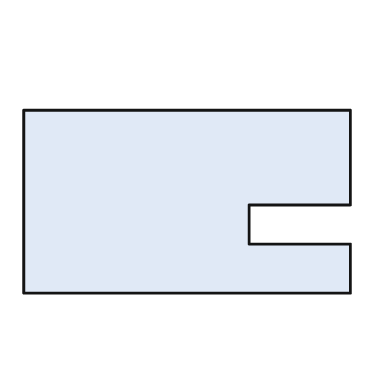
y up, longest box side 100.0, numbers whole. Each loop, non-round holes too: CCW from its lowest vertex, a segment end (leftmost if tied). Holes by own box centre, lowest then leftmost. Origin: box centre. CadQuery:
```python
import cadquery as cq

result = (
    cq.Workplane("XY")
    .moveTo(-50.0, -28.0)
    .lineTo(50.0, -28.0)
    .lineTo(50.0, -13.0)
    .lineTo(19.0, -13.0)
    .lineTo(19.0, -1.0)
    .lineTo(50.0, -1.0)
    .lineTo(50.0, 28.0)
    .lineTo(-50.0, 28.0)
    .close()
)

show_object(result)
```